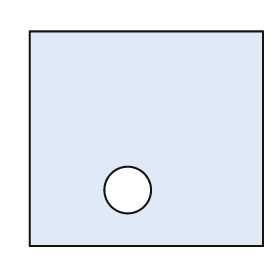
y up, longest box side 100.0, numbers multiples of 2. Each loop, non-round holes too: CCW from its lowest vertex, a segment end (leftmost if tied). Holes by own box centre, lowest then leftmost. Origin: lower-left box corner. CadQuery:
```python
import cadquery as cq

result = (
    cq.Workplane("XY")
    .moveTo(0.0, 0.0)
    .lineTo(100.0, 0.0)
    .lineTo(100.0, 92.0)
    .lineTo(0.0, 92.0)
    .close()
    .moveTo(42.0, 24.0)
    .circle(10.0)
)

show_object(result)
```